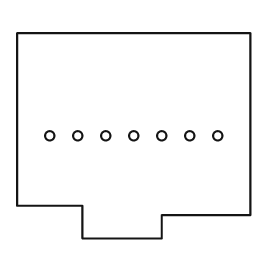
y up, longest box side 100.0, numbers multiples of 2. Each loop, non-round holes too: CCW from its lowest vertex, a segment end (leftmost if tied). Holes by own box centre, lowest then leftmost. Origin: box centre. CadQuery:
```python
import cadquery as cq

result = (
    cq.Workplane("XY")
    .moveTo(-22.0, -44.0)
    .lineTo(12.0, -44.0)
    .lineTo(12.0, -34.0)
    .lineTo(50.0, -34.0)
    .lineTo(50.0, 44.0)
    .lineTo(-50.0, 44.0)
    .lineTo(-50.0, -30.0)
    .lineTo(-22.0, -30.0)
    .close()
    .moveTo(-36.0, 0.0)
    .circle(2.0)
    .moveTo(-24.0, 0.0)
    .circle(2.0)
    .moveTo(-12.0, 0.0)
    .circle(2.0)
    .moveTo(0.0, 0.0)
    .circle(2.0)
    .moveTo(12.0, 0.0)
    .circle(2.0)
    .moveTo(24.0, 0.0)
    .circle(2.0)
    .moveTo(36.0, 0.0)
    .circle(2.0)
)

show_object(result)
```